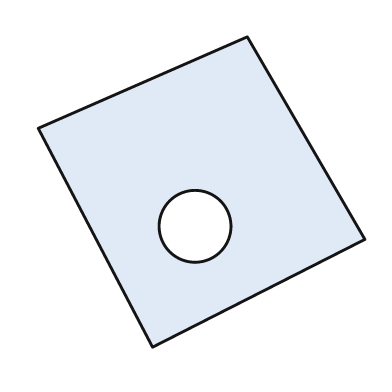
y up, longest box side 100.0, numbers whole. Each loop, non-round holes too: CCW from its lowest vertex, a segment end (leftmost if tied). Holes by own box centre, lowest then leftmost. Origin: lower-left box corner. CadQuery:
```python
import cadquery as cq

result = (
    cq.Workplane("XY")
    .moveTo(35.0, 0.0)
    .lineTo(100.0, 33.0)
    .lineTo(64.0, 95.0)
    .lineTo(0.0, 67.0)
    .close()
    .moveTo(48.0, 37.0)
    .circle(11.0)
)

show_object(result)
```